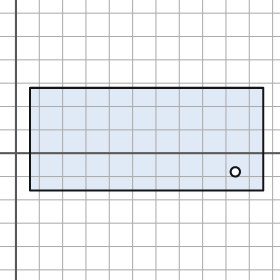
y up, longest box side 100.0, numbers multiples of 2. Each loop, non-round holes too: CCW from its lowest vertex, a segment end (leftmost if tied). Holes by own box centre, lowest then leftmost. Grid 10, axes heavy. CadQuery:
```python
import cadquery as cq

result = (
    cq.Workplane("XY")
    .moveTo(6.0, -16.0)
    .lineTo(106.0, -16.0)
    .lineTo(106.0, 28.0)
    .lineTo(6.0, 28.0)
    .close()
    .moveTo(94.0, -8.0)
    .circle(2.0)
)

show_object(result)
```